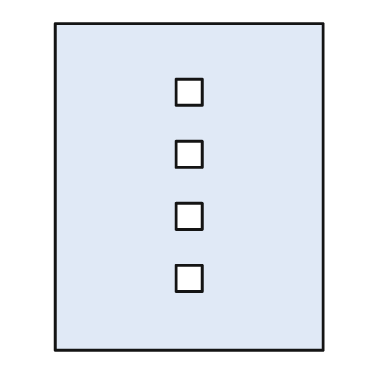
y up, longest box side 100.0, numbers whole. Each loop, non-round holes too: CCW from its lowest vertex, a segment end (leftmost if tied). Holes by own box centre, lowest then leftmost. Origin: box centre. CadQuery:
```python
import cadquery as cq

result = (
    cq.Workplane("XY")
    .moveTo(-41.0, -50.0)
    .lineTo(41.0, -50.0)
    .lineTo(41.0, 50.0)
    .lineTo(-41.0, 50.0)
    .close()
    .moveTo(-4.0, -32.0)
    .lineTo(4.0, -32.0)
    .lineTo(4.0, -24.0)
    .lineTo(-4.0, -24.0)
    .close()
    .moveTo(-4.0, -13.0)
    .lineTo(4.0, -13.0)
    .lineTo(4.0, -5.0)
    .lineTo(-4.0, -5.0)
    .close()
    .moveTo(-4.0, 6.0)
    .lineTo(4.0, 6.0)
    .lineTo(4.0, 14.0)
    .lineTo(-4.0, 14.0)
    .close()
    .moveTo(-4.0, 25.0)
    .lineTo(4.0, 25.0)
    .lineTo(4.0, 33.0)
    .lineTo(-4.0, 33.0)
    .close()
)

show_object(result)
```